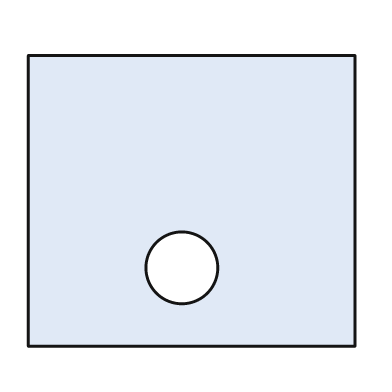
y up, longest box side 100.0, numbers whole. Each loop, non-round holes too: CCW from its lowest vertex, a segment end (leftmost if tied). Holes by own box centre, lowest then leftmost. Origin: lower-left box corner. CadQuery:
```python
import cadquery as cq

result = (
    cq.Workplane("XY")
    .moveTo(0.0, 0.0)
    .lineTo(100.0, 0.0)
    .lineTo(100.0, 89.0)
    .lineTo(0.0, 89.0)
    .close()
    .moveTo(47.0, 24.0)
    .circle(11.0)
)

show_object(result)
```